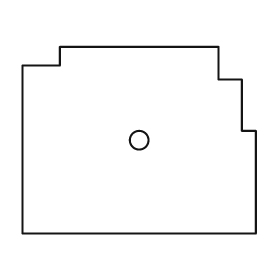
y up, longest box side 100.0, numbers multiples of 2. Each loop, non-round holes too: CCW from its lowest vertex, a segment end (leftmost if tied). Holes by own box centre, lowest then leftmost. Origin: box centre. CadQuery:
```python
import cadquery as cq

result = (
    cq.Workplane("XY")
    .moveTo(-50.0, -40.0)
    .lineTo(50.0, -40.0)
    .lineTo(50.0, 4.0)
    .lineTo(44.0, 4.0)
    .lineTo(44.0, 26.0)
    .lineTo(34.0, 26.0)
    .lineTo(34.0, 40.0)
    .lineTo(-34.0, 40.0)
    .lineTo(-34.0, 32.0)
    .lineTo(-50.0, 32.0)
    .close()
    .moveTo(0.0, 0.0)
    .circle(4.0)
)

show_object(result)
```